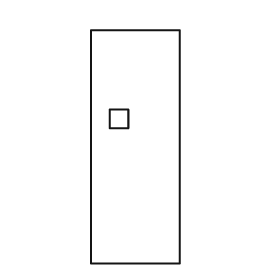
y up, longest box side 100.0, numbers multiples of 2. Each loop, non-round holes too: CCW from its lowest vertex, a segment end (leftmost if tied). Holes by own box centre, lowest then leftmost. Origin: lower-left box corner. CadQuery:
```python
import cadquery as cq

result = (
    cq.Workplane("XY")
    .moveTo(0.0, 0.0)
    .lineTo(38.0, 0.0)
    .lineTo(38.0, 100.0)
    .lineTo(0.0, 100.0)
    .close()
    .moveTo(8.0, 58.0)
    .lineTo(16.0, 58.0)
    .lineTo(16.0, 66.0)
    .lineTo(8.0, 66.0)
    .close()
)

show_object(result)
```